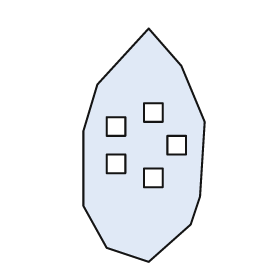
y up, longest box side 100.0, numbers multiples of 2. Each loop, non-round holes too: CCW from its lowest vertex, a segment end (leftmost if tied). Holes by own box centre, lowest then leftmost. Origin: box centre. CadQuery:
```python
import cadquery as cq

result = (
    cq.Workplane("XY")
    .moveTo(2.0, -50.0)
    .lineTo(20.0, -34.0)
    .lineTo(24.0, -22.0)
    .lineTo(26.0, 10.0)
    .lineTo(16.0, 34.0)
    .lineTo(2.0, 50.0)
    .lineTo(-20.0, 26.0)
    .lineTo(-26.0, 6.0)
    .lineTo(-26.0, -26.0)
    .lineTo(-16.0, -44.0)
    .close()
    .moveTo(0.0, -18.0)
    .lineTo(8.0, -18.0)
    .lineTo(8.0, -10.0)
    .lineTo(0.0, -10.0)
    .close()
    .moveTo(-16.0, -12.0)
    .lineTo(-8.0, -12.0)
    .lineTo(-8.0, -4.0)
    .lineTo(-16.0, -4.0)
    .close()
    .moveTo(10.0, -4.0)
    .lineTo(18.0, -4.0)
    .lineTo(18.0, 4.0)
    .lineTo(10.0, 4.0)
    .close()
    .moveTo(-16.0, 4.0)
    .lineTo(-8.0, 4.0)
    .lineTo(-8.0, 12.0)
    .lineTo(-16.0, 12.0)
    .close()
    .moveTo(0.0, 10.0)
    .lineTo(8.0, 10.0)
    .lineTo(8.0, 18.0)
    .lineTo(0.0, 18.0)
    .close()
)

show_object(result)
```